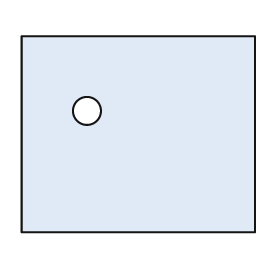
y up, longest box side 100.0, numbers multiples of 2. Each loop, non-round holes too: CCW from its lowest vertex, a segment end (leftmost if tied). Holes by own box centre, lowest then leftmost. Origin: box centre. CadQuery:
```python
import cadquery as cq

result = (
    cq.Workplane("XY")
    .moveTo(-50.0, -42.0)
    .lineTo(50.0, -42.0)
    .lineTo(50.0, 42.0)
    .lineTo(-50.0, 42.0)
    .close()
    .moveTo(-22.0, 10.0)
    .circle(6.0)
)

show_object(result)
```